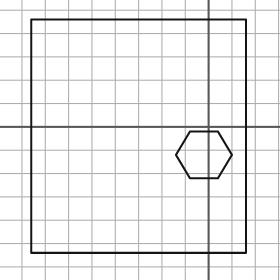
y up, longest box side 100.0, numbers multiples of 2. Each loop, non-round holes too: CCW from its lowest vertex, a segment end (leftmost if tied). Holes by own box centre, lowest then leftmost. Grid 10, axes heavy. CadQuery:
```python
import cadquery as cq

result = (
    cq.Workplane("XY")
    .moveTo(-76.0, -54.0)
    .lineTo(16.0, -54.0)
    .lineTo(16.0, 46.0)
    .lineTo(-76.0, 46.0)
    .close()
    .moveTo(-8.0, -22.0)
    .lineTo(4.0, -22.0)
    .lineTo(10.0, -12.0)
    .lineTo(4.0, -2.0)
    .lineTo(-8.0, -2.0)
    .lineTo(-14.0, -12.0)
    .close()
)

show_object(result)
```